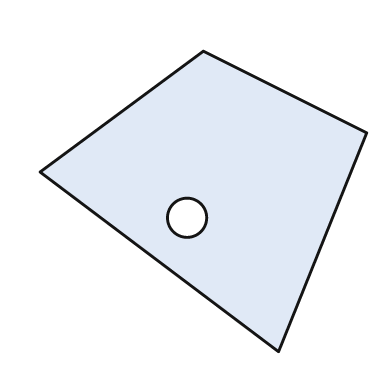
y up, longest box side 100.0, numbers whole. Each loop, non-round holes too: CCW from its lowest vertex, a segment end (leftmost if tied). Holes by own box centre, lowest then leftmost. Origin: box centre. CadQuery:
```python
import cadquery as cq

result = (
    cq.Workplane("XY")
    .moveTo(23.0, -46.0)
    .lineTo(50.0, 21.0)
    .lineTo(0.0, 46.0)
    .lineTo(-50.0, 9.0)
    .close()
    .moveTo(-5.0, -5.0)
    .circle(6.0)
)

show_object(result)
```